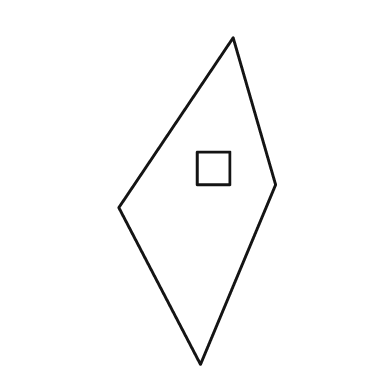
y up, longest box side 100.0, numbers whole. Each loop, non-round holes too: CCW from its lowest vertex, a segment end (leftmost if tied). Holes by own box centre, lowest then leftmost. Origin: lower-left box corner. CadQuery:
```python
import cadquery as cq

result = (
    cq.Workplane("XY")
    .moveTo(25.0, 0.0)
    .lineTo(48.0, 55.0)
    .lineTo(35.0, 100.0)
    .lineTo(0.0, 48.0)
    .close()
    .moveTo(24.0, 55.0)
    .lineTo(34.0, 55.0)
    .lineTo(34.0, 65.0)
    .lineTo(24.0, 65.0)
    .close()
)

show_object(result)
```